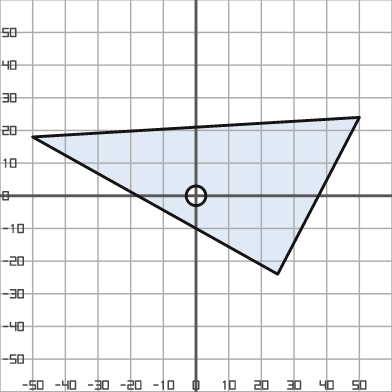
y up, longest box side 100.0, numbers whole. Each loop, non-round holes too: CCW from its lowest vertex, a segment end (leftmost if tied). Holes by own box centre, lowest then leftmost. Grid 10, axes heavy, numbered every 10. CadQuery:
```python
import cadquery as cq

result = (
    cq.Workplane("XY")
    .moveTo(25.0, -24.0)
    .lineTo(50.0, 24.0)
    .lineTo(-50.0, 18.0)
    .close()
    .moveTo(0.0, 0.0)
    .circle(3.0)
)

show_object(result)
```